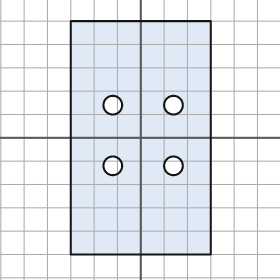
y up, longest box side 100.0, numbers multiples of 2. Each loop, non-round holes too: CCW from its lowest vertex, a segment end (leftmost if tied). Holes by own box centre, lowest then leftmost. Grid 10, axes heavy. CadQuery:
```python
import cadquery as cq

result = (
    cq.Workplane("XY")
    .moveTo(-30.0, -50.0)
    .lineTo(30.0, -50.0)
    .lineTo(30.0, 50.0)
    .lineTo(-30.0, 50.0)
    .close()
    .moveTo(-12.0, -12.0)
    .circle(4.0)
    .moveTo(14.0, -12.0)
    .circle(4.0)
    .moveTo(-12.0, 14.0)
    .circle(4.0)
    .moveTo(14.0, 14.0)
    .circle(4.0)
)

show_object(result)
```